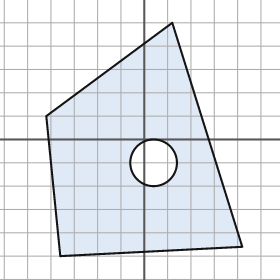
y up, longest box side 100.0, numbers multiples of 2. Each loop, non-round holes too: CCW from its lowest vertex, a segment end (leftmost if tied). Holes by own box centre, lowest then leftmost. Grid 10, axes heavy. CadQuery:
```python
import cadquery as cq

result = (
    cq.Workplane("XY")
    .moveTo(-36.0, -50.0)
    .lineTo(42.0, -46.0)
    .lineTo(12.0, 50.0)
    .lineTo(-42.0, 10.0)
    .close()
    .moveTo(4.0, -10.0)
    .circle(10.0)
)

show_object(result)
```